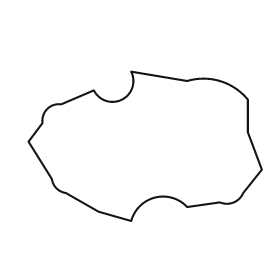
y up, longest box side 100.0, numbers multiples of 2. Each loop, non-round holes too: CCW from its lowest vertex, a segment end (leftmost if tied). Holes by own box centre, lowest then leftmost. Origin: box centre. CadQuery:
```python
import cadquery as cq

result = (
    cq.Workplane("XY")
    .moveTo(-6.0, -32.0)
    .threePointArc((4.0, -22.0), (18.0, -26.0))
    .lineTo(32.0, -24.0)
    .threePointArc((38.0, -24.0), (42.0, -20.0))
    .lineTo(50.0, -10.0)
    .lineTo(44.0, 6.0)
    .lineTo(44.0, 20.0)
    .threePointArc((32.0, 28.0), (18.0, 28.0))
    .lineTo(-6.0, 32.0)
    .threePointArc((-10.0, 20.0), (-22.0, 24.0))
    .lineTo(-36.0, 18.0)
    .threePointArc((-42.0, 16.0), (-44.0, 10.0))
    .lineTo(-50.0, 2.0)
    .lineTo(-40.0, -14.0)
    .threePointArc((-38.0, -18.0), (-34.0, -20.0))
    .lineTo(-20.0, -28.0)
    .close()
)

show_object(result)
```